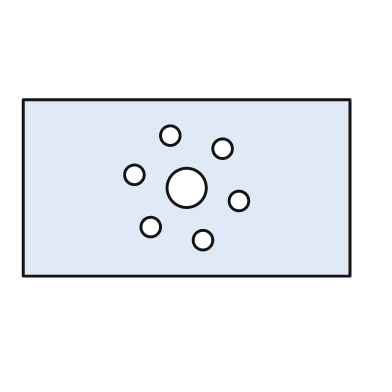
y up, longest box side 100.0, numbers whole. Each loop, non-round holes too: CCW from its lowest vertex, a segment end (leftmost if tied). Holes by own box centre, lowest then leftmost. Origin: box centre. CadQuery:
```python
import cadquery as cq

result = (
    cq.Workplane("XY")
    .moveTo(-50.0, -27.0)
    .lineTo(50.0, -27.0)
    .lineTo(50.0, 27.0)
    .lineTo(-50.0, 27.0)
    .close()
    .moveTo(5.0, -16.0)
    .circle(3.0)
    .moveTo(-11.0, -12.0)
    .circle(3.0)
    .moveTo(16.0, -4.0)
    .circle(3.0)
    .moveTo(0.0, 0.0)
    .circle(6.0)
    .moveTo(-16.0, 4.0)
    .circle(3.0)
    .moveTo(11.0, 12.0)
    .circle(3.0)
    .moveTo(-5.0, 16.0)
    .circle(3.0)
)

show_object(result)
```